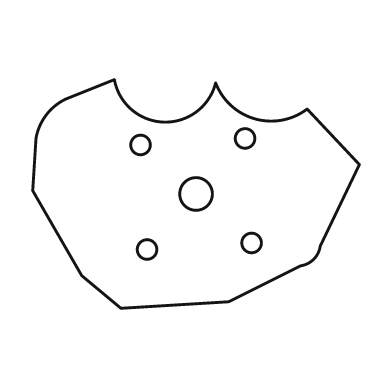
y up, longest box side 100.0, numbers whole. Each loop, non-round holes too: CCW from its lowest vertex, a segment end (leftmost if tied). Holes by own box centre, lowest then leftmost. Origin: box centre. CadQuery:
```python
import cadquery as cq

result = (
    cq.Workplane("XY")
    .moveTo(-23.0, -35.0)
    .lineTo(10.0, -33.0)
    .lineTo(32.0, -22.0)
    .threePointArc((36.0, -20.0), (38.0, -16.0))
    .lineTo(50.0, 9.0)
    .lineTo(34.0, 26.0)
    .threePointArc((18.0, 23.0), (6.0, 34.0))
    .threePointArc((-10.0, 22.0), (-25.0, 35.0))
    .lineTo(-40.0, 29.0)
    .threePointArc((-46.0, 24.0), (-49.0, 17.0))
    .lineTo(-50.0, 1.0)
    .lineTo(-35.0, -25.0)
    .close()
    .moveTo(-15.0, -17.0)
    .circle(3.0)
    .moveTo(17.0, -15.0)
    .circle(3.0)
    .moveTo(0.0, 0.0)
    .circle(5.0)
    .moveTo(-17.0, 15.0)
    .circle(3.0)
    .moveTo(15.0, 17.0)
    .circle(3.0)
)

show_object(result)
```